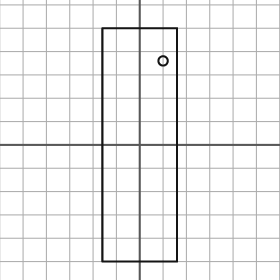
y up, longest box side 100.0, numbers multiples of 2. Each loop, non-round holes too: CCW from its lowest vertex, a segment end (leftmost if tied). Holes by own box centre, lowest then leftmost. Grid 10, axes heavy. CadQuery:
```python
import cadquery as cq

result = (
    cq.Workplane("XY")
    .moveTo(-16.0, -50.0)
    .lineTo(16.0, -50.0)
    .lineTo(16.0, 50.0)
    .lineTo(-16.0, 50.0)
    .close()
    .moveTo(10.0, 36.0)
    .circle(2.0)
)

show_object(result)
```